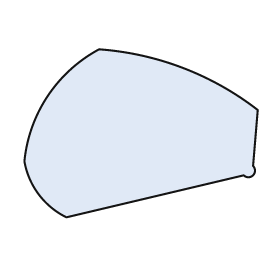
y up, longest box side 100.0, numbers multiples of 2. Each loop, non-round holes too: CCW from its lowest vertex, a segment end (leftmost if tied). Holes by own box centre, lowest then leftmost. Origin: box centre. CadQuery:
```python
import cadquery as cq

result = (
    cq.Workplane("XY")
    .moveTo(-32.0, -36.0)
    .lineTo(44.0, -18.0)
    .threePointArc((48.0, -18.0), (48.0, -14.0))
    .lineTo(50.0, 10.0)
    .threePointArc((18.0, 28.0), (-18.0, 36.0))
    .threePointArc((-40.0, 16.0), (-50.0, -12.0))
    .threePointArc((-44.0, -26.0), (-32.0, -36.0))
    .close()
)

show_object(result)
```